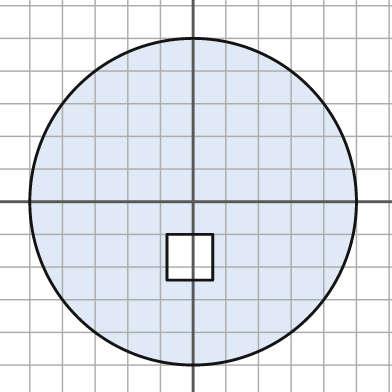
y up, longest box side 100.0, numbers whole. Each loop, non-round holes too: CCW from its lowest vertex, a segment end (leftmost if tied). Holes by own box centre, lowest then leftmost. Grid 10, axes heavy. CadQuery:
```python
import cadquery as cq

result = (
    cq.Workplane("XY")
    .moveTo(0.0, 0.0)
    .circle(50.0)
    .moveTo(-8.0, -24.0)
    .lineTo(6.0, -24.0)
    .lineTo(6.0, -10.0)
    .lineTo(-8.0, -10.0)
    .close()
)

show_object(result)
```